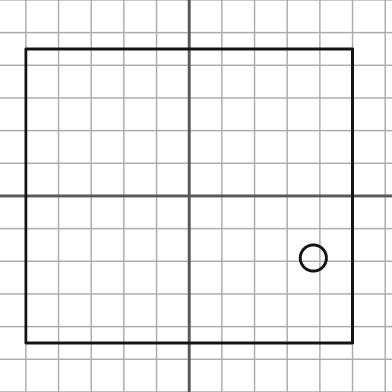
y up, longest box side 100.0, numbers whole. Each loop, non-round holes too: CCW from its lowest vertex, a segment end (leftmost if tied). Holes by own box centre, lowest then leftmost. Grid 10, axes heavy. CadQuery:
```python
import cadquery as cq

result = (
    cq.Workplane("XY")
    .moveTo(-50.0, -45.0)
    .lineTo(50.0, -45.0)
    .lineTo(50.0, 45.0)
    .lineTo(-50.0, 45.0)
    .close()
    .moveTo(38.0, -19.0)
    .circle(4.0)
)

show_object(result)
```